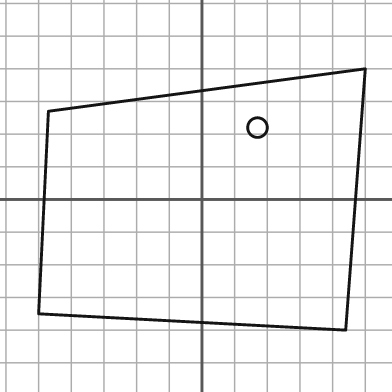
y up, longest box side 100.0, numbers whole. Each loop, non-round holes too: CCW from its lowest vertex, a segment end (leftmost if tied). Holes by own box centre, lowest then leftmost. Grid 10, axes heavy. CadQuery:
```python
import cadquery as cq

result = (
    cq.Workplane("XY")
    .moveTo(44.0, -40.0)
    .lineTo(50.0, 40.0)
    .lineTo(-47.0, 27.0)
    .lineTo(-50.0, -35.0)
    .close()
    .moveTo(17.0, 22.0)
    .circle(3.0)
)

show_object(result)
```